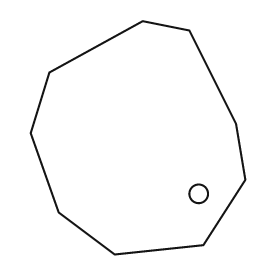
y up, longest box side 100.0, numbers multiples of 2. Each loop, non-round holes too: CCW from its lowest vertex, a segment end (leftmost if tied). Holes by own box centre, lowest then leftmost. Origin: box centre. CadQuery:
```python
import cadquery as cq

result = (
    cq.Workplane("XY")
    .moveTo(-10.0, -50.0)
    .lineTo(28.0, -46.0)
    .lineTo(46.0, -18.0)
    .lineTo(42.0, 6.0)
    .lineTo(22.0, 46.0)
    .lineTo(2.0, 50.0)
    .lineTo(-38.0, 28.0)
    .lineTo(-46.0, 2.0)
    .lineTo(-34.0, -32.0)
    .close()
    .moveTo(26.0, -24.0)
    .circle(4.0)
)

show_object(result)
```